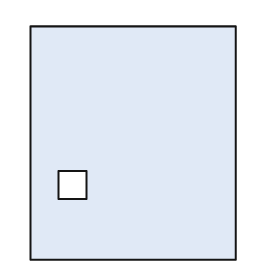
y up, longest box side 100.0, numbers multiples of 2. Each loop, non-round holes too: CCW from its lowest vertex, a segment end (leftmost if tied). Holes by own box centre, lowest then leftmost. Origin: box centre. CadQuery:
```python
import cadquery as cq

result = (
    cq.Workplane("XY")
    .moveTo(-44.0, -50.0)
    .lineTo(44.0, -50.0)
    .lineTo(44.0, 50.0)
    .lineTo(-44.0, 50.0)
    .close()
    .moveTo(-32.0, -24.0)
    .lineTo(-20.0, -24.0)
    .lineTo(-20.0, -12.0)
    .lineTo(-32.0, -12.0)
    .close()
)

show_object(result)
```